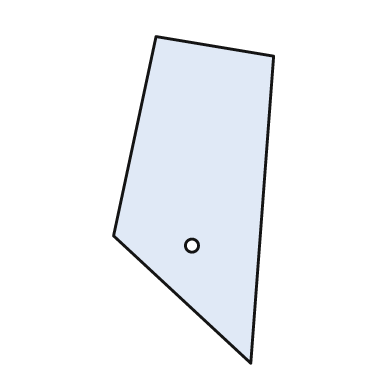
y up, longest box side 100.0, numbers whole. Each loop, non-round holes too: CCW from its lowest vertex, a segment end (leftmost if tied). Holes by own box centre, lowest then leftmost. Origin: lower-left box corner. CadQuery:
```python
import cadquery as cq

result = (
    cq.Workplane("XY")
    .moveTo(42.0, 0.0)
    .lineTo(49.0, 94.0)
    .lineTo(13.0, 100.0)
    .lineTo(0.0, 39.0)
    .close()
    .moveTo(24.0, 36.0)
    .circle(2.0)
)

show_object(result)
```